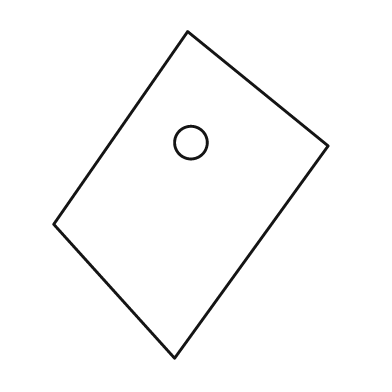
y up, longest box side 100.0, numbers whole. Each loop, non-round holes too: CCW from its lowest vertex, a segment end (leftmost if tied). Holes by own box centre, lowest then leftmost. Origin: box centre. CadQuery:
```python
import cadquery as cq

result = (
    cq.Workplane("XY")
    .moveTo(-5.0, -50.0)
    .lineTo(42.0, 15.0)
    .lineTo(-1.0, 50.0)
    .lineTo(-42.0, -9.0)
    .close()
    .moveTo(0.0, 16.0)
    .circle(5.0)
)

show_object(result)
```